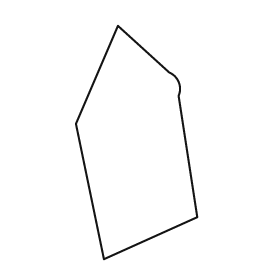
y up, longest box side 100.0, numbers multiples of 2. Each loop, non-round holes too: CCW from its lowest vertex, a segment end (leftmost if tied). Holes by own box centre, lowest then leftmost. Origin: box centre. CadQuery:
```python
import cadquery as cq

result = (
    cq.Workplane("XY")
    .moveTo(-14.0, -50.0)
    .lineTo(26.0, -32.0)
    .lineTo(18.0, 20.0)
    .threePointArc((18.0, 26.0), (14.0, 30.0))
    .lineTo(-8.0, 50.0)
    .lineTo(-26.0, 8.0)
    .close()
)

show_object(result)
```